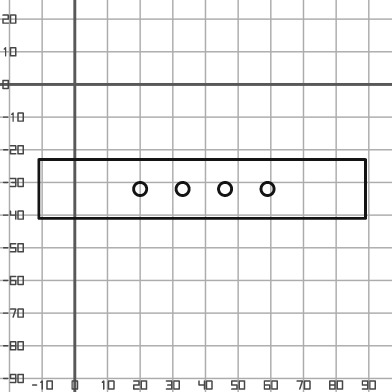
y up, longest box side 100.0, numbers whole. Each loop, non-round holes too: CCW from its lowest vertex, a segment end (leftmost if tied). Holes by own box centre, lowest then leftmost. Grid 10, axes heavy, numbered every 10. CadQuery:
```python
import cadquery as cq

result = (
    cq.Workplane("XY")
    .moveTo(-11.0, -41.0)
    .lineTo(89.0, -41.0)
    .lineTo(89.0, -23.0)
    .lineTo(-11.0, -23.0)
    .close()
    .moveTo(20.0, -32.0)
    .circle(2.0)
    .moveTo(33.0, -32.0)
    .circle(2.0)
    .moveTo(46.0, -32.0)
    .circle(2.0)
    .moveTo(59.0, -32.0)
    .circle(2.0)
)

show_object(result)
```